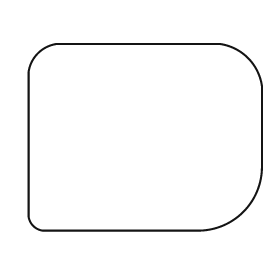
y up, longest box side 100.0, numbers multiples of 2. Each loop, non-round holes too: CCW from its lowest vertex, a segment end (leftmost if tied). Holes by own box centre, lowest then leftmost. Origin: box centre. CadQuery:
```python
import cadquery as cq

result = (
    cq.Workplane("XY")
    .moveTo(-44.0, -40.0)
    .lineTo(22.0, -40.0)
    .threePointArc((42.0, -32.0), (50.0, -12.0))
    .lineTo(50.0, 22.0)
    .threePointArc((44.0, 34.0), (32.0, 40.0))
    .lineTo(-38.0, 40.0)
    .threePointArc((-46.0, 36.0), (-50.0, 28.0))
    .lineTo(-50.0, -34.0)
    .threePointArc((-48.0, -38.0), (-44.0, -40.0))
    .close()
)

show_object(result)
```